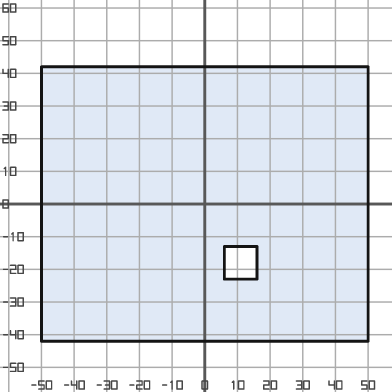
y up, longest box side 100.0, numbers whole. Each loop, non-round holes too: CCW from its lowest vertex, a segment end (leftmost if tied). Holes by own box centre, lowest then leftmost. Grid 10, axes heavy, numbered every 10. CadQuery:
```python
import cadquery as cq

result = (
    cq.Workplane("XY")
    .moveTo(-50.0, -42.0)
    .lineTo(50.0, -42.0)
    .lineTo(50.0, 42.0)
    .lineTo(-50.0, 42.0)
    .close()
    .moveTo(6.0, -23.0)
    .lineTo(16.0, -23.0)
    .lineTo(16.0, -13.0)
    .lineTo(6.0, -13.0)
    .close()
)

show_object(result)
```